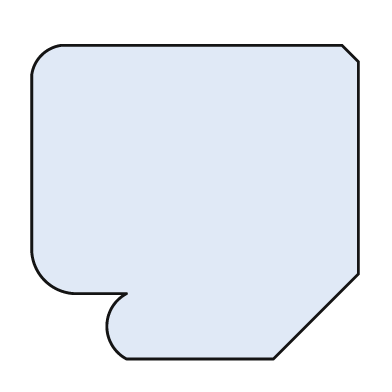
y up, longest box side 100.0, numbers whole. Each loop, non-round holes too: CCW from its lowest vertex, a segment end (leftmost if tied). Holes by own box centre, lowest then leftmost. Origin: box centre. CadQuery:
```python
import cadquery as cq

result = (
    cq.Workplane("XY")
    .moveTo(-21.0, -48.0)
    .lineTo(24.0, -48.0)
    .lineTo(50.0, -22.0)
    .lineTo(50.0, 43.0)
    .lineTo(45.0, 48.0)
    .lineTo(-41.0, 48.0)
    .threePointArc((-47.0, 45.0), (-50.0, 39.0))
    .lineTo(-50.0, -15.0)
    .threePointArc((-46.0, -24.0), (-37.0, -28.0))
    .lineTo(-21.0, -28.0)
    .threePointArc((-27.0, -38.0), (-21.0, -48.0))
    .close()
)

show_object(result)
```